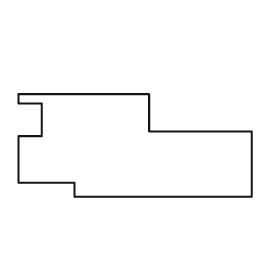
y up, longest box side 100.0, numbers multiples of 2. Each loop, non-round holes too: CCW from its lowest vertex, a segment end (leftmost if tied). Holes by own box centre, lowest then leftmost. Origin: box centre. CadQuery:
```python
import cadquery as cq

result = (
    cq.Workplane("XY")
    .moveTo(-26.0, -22.0)
    .lineTo(50.0, -22.0)
    .lineTo(50.0, 6.0)
    .lineTo(6.0, 6.0)
    .lineTo(6.0, 22.0)
    .lineTo(-50.0, 22.0)
    .lineTo(-50.0, 18.0)
    .lineTo(-40.0, 18.0)
    .lineTo(-40.0, 4.0)
    .lineTo(-50.0, 4.0)
    .lineTo(-50.0, -16.0)
    .lineTo(-26.0, -16.0)
    .close()
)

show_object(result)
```